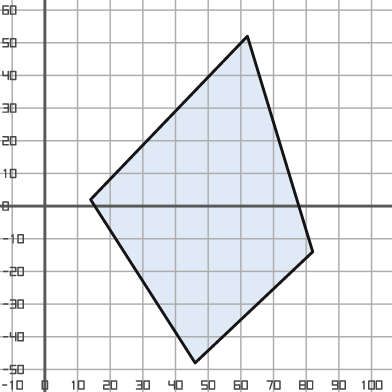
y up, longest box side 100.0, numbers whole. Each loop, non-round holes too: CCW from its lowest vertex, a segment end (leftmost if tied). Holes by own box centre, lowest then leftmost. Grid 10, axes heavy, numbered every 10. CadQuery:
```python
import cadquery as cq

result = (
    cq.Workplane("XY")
    .moveTo(46.0, -48.0)
    .lineTo(82.0, -14.0)
    .lineTo(62.0, 52.0)
    .lineTo(14.0, 2.0)
    .close()
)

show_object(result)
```